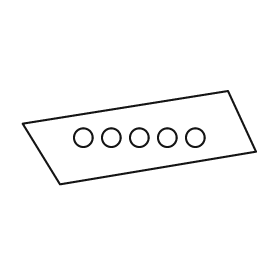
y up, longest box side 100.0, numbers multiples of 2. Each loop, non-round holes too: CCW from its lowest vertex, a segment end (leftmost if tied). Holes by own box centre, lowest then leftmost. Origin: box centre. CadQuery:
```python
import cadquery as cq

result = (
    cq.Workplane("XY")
    .moveTo(-34.0, -20.0)
    .lineTo(50.0, -6.0)
    .lineTo(38.0, 20.0)
    .lineTo(-50.0, 6.0)
    .close()
    .moveTo(-24.0, 0.0)
    .circle(4.0)
    .moveTo(-12.0, 0.0)
    .circle(4.0)
    .moveTo(0.0, 0.0)
    .circle(4.0)
    .moveTo(12.0, 0.0)
    .circle(4.0)
    .moveTo(24.0, 0.0)
    .circle(4.0)
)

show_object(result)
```